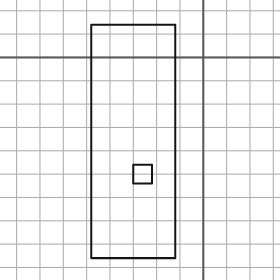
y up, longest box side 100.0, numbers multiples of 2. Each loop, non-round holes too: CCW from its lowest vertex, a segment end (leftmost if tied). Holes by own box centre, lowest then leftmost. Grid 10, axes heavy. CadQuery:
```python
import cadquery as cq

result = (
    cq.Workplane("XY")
    .moveTo(-48.0, -86.0)
    .lineTo(-12.0, -86.0)
    .lineTo(-12.0, 14.0)
    .lineTo(-48.0, 14.0)
    .close()
    .moveTo(-30.0, -54.0)
    .lineTo(-22.0, -54.0)
    .lineTo(-22.0, -46.0)
    .lineTo(-30.0, -46.0)
    .close()
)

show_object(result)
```